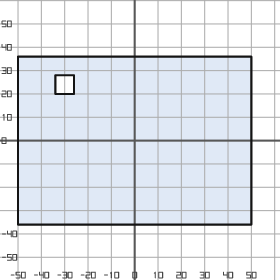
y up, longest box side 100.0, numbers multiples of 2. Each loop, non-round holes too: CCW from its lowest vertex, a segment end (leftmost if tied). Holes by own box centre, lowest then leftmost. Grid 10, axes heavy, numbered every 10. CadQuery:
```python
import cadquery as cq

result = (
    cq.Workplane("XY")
    .moveTo(-50.0, -36.0)
    .lineTo(50.0, -36.0)
    .lineTo(50.0, 36.0)
    .lineTo(-50.0, 36.0)
    .close()
    .moveTo(-34.0, 20.0)
    .lineTo(-26.0, 20.0)
    .lineTo(-26.0, 28.0)
    .lineTo(-34.0, 28.0)
    .close()
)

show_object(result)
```